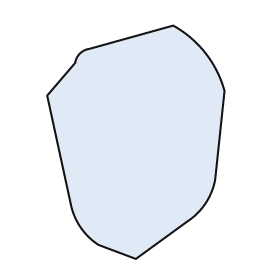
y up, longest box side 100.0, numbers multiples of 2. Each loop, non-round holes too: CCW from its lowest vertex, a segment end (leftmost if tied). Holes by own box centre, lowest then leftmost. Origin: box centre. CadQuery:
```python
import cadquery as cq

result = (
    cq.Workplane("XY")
    .moveTo(0.0, -50.0)
    .lineTo(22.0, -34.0)
    .threePointArc((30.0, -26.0), (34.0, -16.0))
    .lineTo(38.0, 22.0)
    .threePointArc((30.0, 38.0), (16.0, 50.0))
    .lineTo(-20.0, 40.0)
    .threePointArc((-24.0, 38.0), (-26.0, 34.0))
    .lineTo(-38.0, 20.0)
    .lineTo(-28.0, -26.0)
    .threePointArc((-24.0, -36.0), (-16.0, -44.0))
    .close()
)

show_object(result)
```